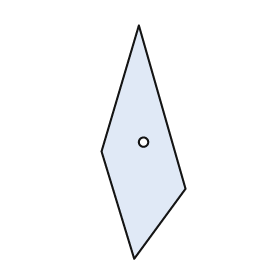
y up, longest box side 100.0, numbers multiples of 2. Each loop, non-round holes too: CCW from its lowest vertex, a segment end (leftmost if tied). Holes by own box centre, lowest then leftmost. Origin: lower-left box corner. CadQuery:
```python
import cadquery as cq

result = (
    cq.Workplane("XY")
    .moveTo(14.0, 0.0)
    .lineTo(36.0, 30.0)
    .lineTo(16.0, 100.0)
    .lineTo(0.0, 46.0)
    .close()
    .moveTo(18.0, 50.0)
    .circle(2.0)
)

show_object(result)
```